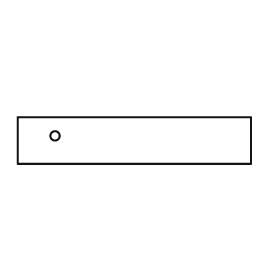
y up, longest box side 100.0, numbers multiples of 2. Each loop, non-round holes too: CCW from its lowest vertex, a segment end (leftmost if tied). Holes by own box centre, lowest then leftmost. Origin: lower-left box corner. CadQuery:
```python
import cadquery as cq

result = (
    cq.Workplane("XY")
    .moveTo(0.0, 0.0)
    .lineTo(100.0, 0.0)
    .lineTo(100.0, 20.0)
    .lineTo(0.0, 20.0)
    .close()
    .moveTo(16.0, 12.0)
    .circle(2.0)
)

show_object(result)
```